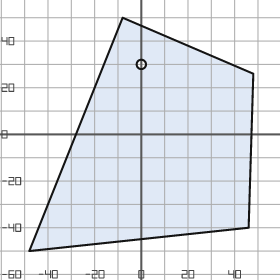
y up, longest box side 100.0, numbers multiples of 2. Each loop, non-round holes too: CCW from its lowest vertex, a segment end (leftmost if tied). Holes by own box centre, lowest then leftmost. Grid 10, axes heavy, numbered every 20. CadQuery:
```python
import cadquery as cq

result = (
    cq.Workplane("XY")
    .moveTo(-48.0, -50.0)
    .lineTo(46.0, -40.0)
    .lineTo(48.0, 26.0)
    .lineTo(-8.0, 50.0)
    .close()
    .moveTo(0.0, 30.0)
    .circle(2.0)
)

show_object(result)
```